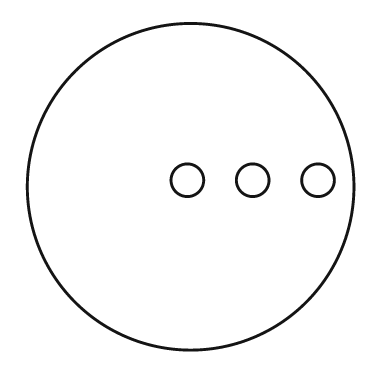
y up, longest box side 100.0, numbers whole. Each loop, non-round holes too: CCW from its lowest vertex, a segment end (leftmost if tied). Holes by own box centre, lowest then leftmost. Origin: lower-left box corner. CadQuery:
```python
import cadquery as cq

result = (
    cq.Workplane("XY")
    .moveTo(50.0, 50.0)
    .circle(50.0)
    .moveTo(49.0, 52.0)
    .circle(5.0)
    .moveTo(69.0, 52.0)
    .circle(5.0)
    .moveTo(89.0, 52.0)
    .circle(5.0)
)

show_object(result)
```